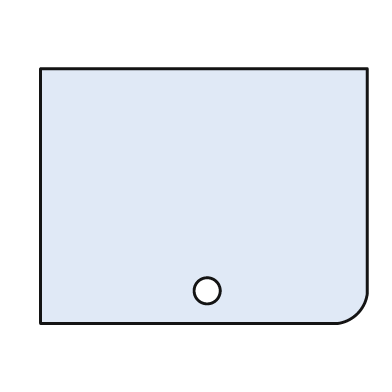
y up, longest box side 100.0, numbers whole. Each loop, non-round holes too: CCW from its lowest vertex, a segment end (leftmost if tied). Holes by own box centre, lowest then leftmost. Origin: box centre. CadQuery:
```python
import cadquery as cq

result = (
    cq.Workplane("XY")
    .moveTo(-50.0, -39.0)
    .lineTo(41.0, -39.0)
    .threePointArc((47.0, -36.0), (50.0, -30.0))
    .lineTo(50.0, 39.0)
    .lineTo(-50.0, 39.0)
    .close()
    .moveTo(1.0, -29.0)
    .circle(4.0)
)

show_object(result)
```